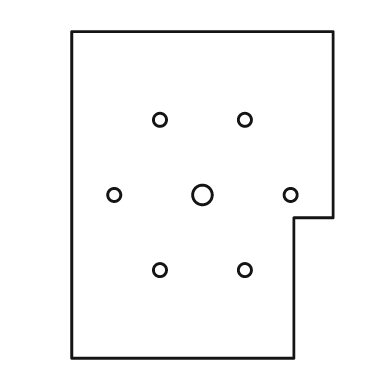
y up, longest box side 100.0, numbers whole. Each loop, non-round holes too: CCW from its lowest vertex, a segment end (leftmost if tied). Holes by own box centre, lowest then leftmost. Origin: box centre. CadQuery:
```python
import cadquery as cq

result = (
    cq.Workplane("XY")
    .moveTo(-40.0, -50.0)
    .lineTo(28.0, -50.0)
    .lineTo(28.0, -7.0)
    .lineTo(40.0, -7.0)
    .lineTo(40.0, 50.0)
    .lineTo(-40.0, 50.0)
    .close()
    .moveTo(-13.0, -23.0)
    .circle(2.0)
    .moveTo(13.0, -23.0)
    .circle(2.0)
    .moveTo(-27.0, 0.0)
    .circle(2.0)
    .moveTo(0.0, 0.0)
    .circle(3.0)
    .moveTo(27.0, 0.0)
    .circle(2.0)
    .moveTo(-13.0, 23.0)
    .circle(2.0)
    .moveTo(13.0, 23.0)
    .circle(2.0)
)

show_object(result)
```